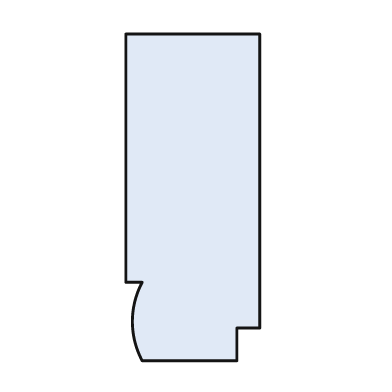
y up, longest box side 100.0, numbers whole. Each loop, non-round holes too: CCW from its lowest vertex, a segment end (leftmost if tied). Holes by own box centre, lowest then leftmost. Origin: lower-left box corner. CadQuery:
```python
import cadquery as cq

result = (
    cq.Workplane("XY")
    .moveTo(5.0, 0.0)
    .lineTo(34.0, 0.0)
    .lineTo(34.0, 10.0)
    .lineTo(41.0, 10.0)
    .lineTo(41.0, 100.0)
    .lineTo(0.0, 100.0)
    .lineTo(0.0, 24.0)
    .lineTo(5.0, 24.0)
    .threePointArc((2.0, 12.0), (5.0, 0.0))
    .close()
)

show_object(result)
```